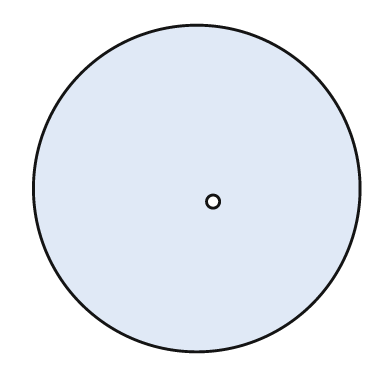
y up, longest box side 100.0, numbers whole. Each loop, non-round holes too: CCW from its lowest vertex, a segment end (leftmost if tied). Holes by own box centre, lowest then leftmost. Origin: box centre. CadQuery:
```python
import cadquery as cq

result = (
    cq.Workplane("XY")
    .moveTo(0.0, 0.0)
    .circle(50.0)
    .moveTo(5.0, -4.0)
    .circle(2.0)
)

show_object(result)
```